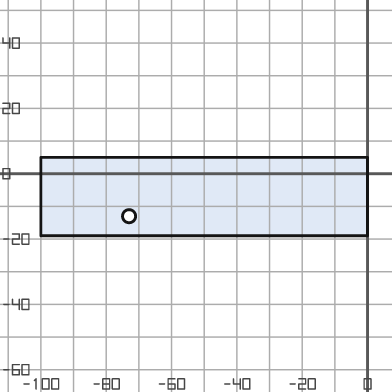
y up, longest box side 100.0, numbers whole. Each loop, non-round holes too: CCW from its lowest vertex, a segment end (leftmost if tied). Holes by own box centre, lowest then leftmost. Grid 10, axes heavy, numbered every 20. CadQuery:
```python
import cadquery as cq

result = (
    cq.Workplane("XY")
    .moveTo(-100.0, -19.0)
    .lineTo(0.0, -19.0)
    .lineTo(0.0, 5.0)
    .lineTo(-100.0, 5.0)
    .close()
    .moveTo(-73.0, -13.0)
    .circle(2.0)
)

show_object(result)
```